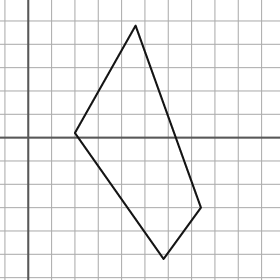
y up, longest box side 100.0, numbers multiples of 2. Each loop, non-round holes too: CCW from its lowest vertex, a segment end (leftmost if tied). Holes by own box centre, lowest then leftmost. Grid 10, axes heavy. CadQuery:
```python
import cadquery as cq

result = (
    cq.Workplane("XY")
    .moveTo(58.0, -52.0)
    .lineTo(74.0, -30.0)
    .lineTo(46.0, 48.0)
    .lineTo(20.0, 2.0)
    .close()
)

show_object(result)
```